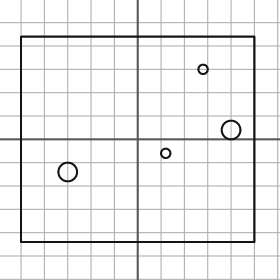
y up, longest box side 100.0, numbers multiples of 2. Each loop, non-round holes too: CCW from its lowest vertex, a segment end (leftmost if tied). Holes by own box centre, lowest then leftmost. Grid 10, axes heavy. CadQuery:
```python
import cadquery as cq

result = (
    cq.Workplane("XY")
    .moveTo(-50.0, -44.0)
    .lineTo(50.0, -44.0)
    .lineTo(50.0, 44.0)
    .lineTo(-50.0, 44.0)
    .close()
    .moveTo(-30.0, -14.0)
    .circle(4.0)
    .moveTo(12.0, -6.0)
    .circle(2.0)
    .moveTo(40.0, 4.0)
    .circle(4.0)
    .moveTo(28.0, 30.0)
    .circle(2.0)
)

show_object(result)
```